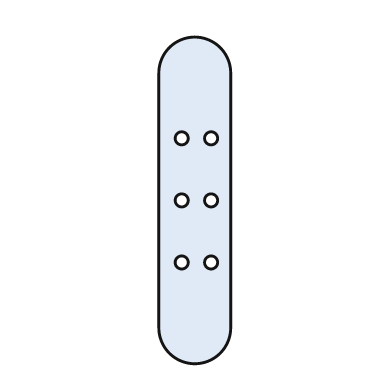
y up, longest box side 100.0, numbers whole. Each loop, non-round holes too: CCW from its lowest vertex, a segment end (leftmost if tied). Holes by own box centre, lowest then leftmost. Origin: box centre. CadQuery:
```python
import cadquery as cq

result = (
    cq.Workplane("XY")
    .moveTo(-11.0, -39.0)
    .threePointArc((0.0, -50.0), (11.0, -39.0))
    .lineTo(11.0, 39.0)
    .threePointArc((0.0, 50.0), (-11.0, 39.0))
    .close()
    .moveTo(-4.0, -19.0)
    .circle(2.0)
    .moveTo(5.0, -19.0)
    .circle(2.0)
    .moveTo(-4.0, 0.0)
    .circle(2.0)
    .moveTo(5.0, 0.0)
    .circle(2.0)
    .moveTo(-4.0, 19.0)
    .circle(2.0)
    .moveTo(5.0, 19.0)
    .circle(2.0)
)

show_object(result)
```